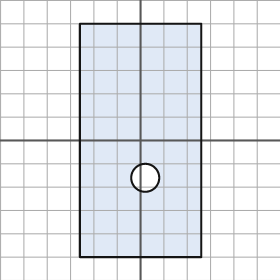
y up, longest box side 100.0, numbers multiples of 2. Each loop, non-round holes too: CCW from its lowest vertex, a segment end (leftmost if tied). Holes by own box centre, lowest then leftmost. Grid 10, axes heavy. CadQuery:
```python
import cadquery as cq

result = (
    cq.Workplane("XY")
    .moveTo(-26.0, -50.0)
    .lineTo(26.0, -50.0)
    .lineTo(26.0, 50.0)
    .lineTo(-26.0, 50.0)
    .close()
    .moveTo(2.0, -16.0)
    .circle(6.0)
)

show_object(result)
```